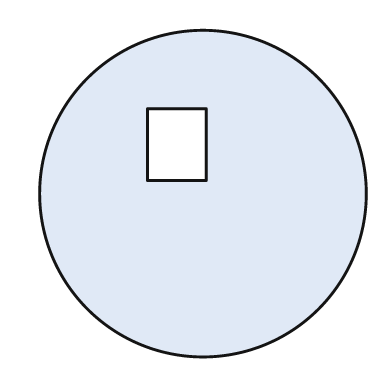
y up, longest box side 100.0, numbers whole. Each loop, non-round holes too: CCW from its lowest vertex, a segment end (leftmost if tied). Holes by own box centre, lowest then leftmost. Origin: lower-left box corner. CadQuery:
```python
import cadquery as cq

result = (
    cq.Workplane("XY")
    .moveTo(50.0, 50.0)
    .circle(50.0)
    .moveTo(33.0, 54.0)
    .lineTo(51.0, 54.0)
    .lineTo(51.0, 76.0)
    .lineTo(33.0, 76.0)
    .close()
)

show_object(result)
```